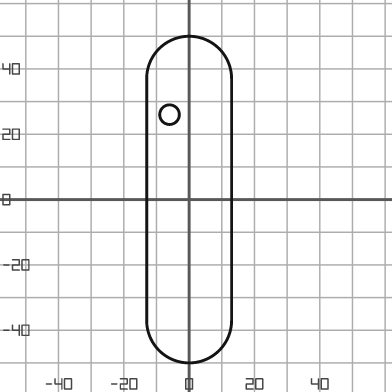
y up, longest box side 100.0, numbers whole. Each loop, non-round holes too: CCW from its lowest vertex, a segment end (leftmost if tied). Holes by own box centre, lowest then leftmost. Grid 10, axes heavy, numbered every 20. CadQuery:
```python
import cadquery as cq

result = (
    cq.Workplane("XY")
    .moveTo(-13.0, -37.0)
    .threePointArc((0.0, -50.0), (13.0, -37.0))
    .lineTo(13.0, 37.0)
    .threePointArc((0.0, 50.0), (-13.0, 37.0))
    .close()
    .moveTo(-6.0, 26.0)
    .circle(3.0)
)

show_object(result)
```